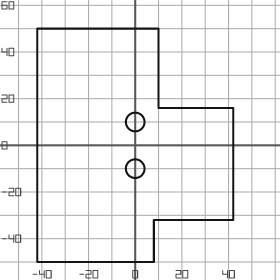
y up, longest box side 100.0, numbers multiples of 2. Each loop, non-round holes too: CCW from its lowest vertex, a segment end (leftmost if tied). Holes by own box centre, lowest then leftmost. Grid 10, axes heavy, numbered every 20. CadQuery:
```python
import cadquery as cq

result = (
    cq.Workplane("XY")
    .moveTo(-42.0, -50.0)
    .lineTo(8.0, -50.0)
    .lineTo(8.0, -32.0)
    .lineTo(42.0, -32.0)
    .lineTo(42.0, 16.0)
    .lineTo(10.0, 16.0)
    .lineTo(10.0, 50.0)
    .lineTo(-42.0, 50.0)
    .close()
    .moveTo(0.0, -10.0)
    .circle(4.0)
    .moveTo(0.0, 10.0)
    .circle(4.0)
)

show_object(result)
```